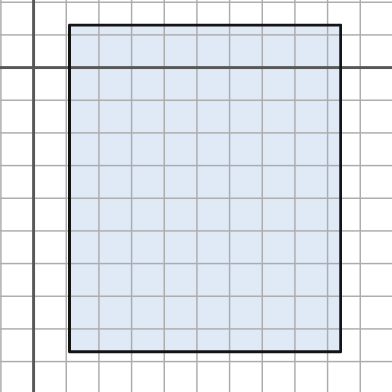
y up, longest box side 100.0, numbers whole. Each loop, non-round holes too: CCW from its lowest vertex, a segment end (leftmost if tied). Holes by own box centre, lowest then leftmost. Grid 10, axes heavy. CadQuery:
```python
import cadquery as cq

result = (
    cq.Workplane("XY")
    .moveTo(11.0, -87.0)
    .lineTo(94.0, -87.0)
    .lineTo(94.0, 13.0)
    .lineTo(11.0, 13.0)
    .close()
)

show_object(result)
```